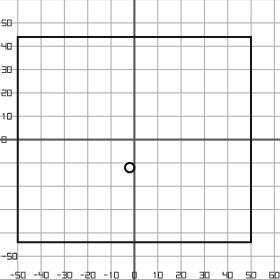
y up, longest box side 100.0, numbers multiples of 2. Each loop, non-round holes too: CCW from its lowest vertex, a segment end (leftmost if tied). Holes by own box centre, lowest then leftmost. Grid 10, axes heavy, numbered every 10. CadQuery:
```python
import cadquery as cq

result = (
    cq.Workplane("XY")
    .moveTo(-50.0, -44.0)
    .lineTo(50.0, -44.0)
    .lineTo(50.0, 44.0)
    .lineTo(-50.0, 44.0)
    .close()
    .moveTo(-2.0, -12.0)
    .circle(2.0)
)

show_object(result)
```